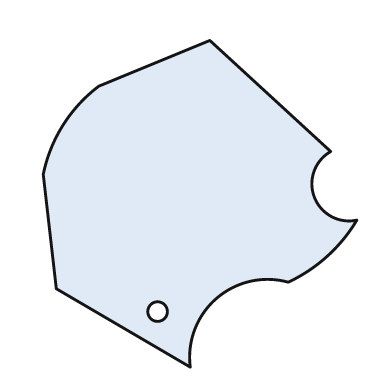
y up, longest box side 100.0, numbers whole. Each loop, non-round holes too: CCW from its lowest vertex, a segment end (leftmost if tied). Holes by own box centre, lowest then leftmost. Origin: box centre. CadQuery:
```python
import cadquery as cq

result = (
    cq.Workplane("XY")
    .moveTo(-3.0, -50.0)
    .threePointArc((5.0, -29.0), (27.0, -24.0))
    .threePointArc((39.0, -16.0), (48.0, -5.0))
    .threePointArc((35.0, 2.0), (40.0, 16.0))
    .lineTo(3.0, 50.0)
    .lineTo(-31.0, 36.0)
    .threePointArc((-42.0, 24.0), (-48.0, 9.0))
    .lineTo(-44.0, -26.0)
    .close()
    .moveTo(-13.0, -33.0)
    .circle(3.0)
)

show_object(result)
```